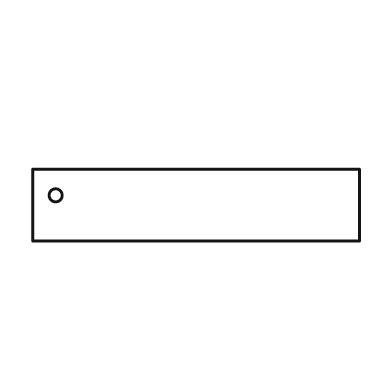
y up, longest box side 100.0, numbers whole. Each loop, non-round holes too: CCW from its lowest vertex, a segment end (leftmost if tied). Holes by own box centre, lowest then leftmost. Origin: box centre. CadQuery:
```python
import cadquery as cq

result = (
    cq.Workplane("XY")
    .moveTo(-50.0, -11.0)
    .lineTo(50.0, -11.0)
    .lineTo(50.0, 11.0)
    .lineTo(-50.0, 11.0)
    .close()
    .moveTo(-43.0, 3.0)
    .circle(2.0)
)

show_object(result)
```